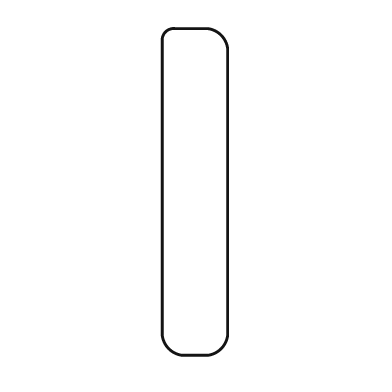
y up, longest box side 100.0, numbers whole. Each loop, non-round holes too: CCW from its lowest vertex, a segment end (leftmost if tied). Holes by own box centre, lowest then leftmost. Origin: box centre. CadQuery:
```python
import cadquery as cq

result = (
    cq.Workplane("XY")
    .moveTo(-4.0, -50.0)
    .lineTo(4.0, -50.0)
    .threePointArc((8.0, -48.0), (10.0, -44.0))
    .lineTo(10.0, 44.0)
    .threePointArc((8.0, 48.0), (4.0, 50.0))
    .lineTo(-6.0, 50.0)
    .threePointArc((-9.0, 49.0), (-10.0, 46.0))
    .lineTo(-10.0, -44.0)
    .threePointArc((-8.0, -48.0), (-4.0, -50.0))
    .close()
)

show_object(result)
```